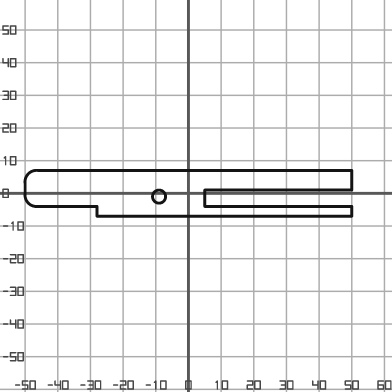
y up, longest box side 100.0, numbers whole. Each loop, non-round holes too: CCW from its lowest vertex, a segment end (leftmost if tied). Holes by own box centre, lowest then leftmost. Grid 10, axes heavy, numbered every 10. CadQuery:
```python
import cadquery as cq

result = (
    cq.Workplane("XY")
    .moveTo(-28.0, -7.0)
    .lineTo(50.0, -7.0)
    .lineTo(50.0, -4.0)
    .lineTo(5.0, -4.0)
    .lineTo(5.0, 1.0)
    .lineTo(50.0, 1.0)
    .lineTo(50.0, 7.0)
    .lineTo(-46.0, 7.0)
    .threePointArc((-49.0, 6.0), (-50.0, 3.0))
    .lineTo(-50.0, 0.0)
    .threePointArc((-49.0, -3.0), (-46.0, -4.0))
    .lineTo(-28.0, -4.0)
    .close()
    .moveTo(-9.0, -1.0)
    .circle(2.0)
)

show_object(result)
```